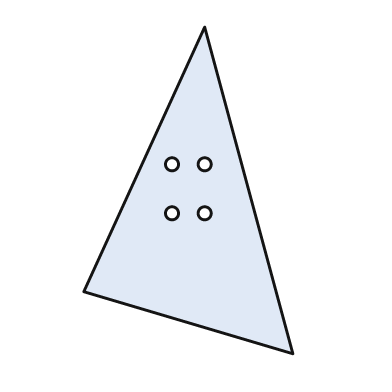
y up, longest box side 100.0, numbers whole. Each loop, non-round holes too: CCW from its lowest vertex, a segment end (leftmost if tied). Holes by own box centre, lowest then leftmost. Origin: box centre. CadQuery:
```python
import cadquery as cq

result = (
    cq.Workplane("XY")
    .moveTo(32.0, -50.0)
    .lineTo(5.0, 50.0)
    .lineTo(-32.0, -31.0)
    .close()
    .moveTo(-5.0, -7.0)
    .circle(2.0)
    .moveTo(5.0, -7.0)
    .circle(2.0)
    .moveTo(-5.0, 8.0)
    .circle(2.0)
    .moveTo(5.0, 8.0)
    .circle(2.0)
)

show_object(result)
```